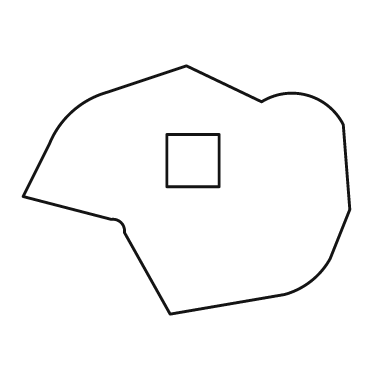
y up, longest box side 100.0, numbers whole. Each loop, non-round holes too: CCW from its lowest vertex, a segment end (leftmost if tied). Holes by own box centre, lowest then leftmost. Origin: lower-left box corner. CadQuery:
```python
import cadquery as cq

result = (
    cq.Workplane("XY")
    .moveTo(45.0, 0.0)
    .lineTo(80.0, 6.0)
    .threePointArc((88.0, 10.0), (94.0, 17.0))
    .lineTo(100.0, 32.0)
    .lineTo(98.0, 58.0)
    .threePointArc((87.0, 67.0), (73.0, 65.0))
    .lineTo(50.0, 76.0)
    .lineTo(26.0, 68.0)
    .threePointArc((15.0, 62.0), (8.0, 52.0))
    .lineTo(0.0, 36.0)
    .lineTo(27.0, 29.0)
    .threePointArc((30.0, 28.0), (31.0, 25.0))
    .close()
    .moveTo(44.0, 39.0)
    .lineTo(60.0, 39.0)
    .lineTo(60.0, 55.0)
    .lineTo(44.0, 55.0)
    .close()
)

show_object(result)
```